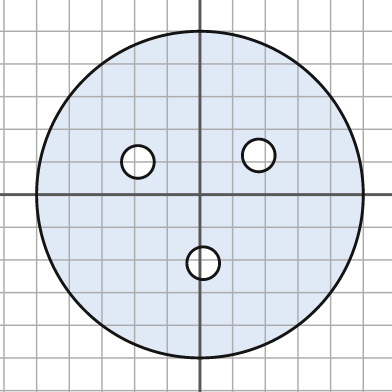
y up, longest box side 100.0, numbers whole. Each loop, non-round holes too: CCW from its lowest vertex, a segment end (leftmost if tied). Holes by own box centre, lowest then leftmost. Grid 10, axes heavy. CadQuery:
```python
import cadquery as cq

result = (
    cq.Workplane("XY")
    .moveTo(0.0, 0.0)
    .circle(50.0)
    .moveTo(1.0, -21.0)
    .circle(5.0)
    .moveTo(-19.0, 10.0)
    .circle(5.0)
    .moveTo(18.0, 12.0)
    .circle(5.0)
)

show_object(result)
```